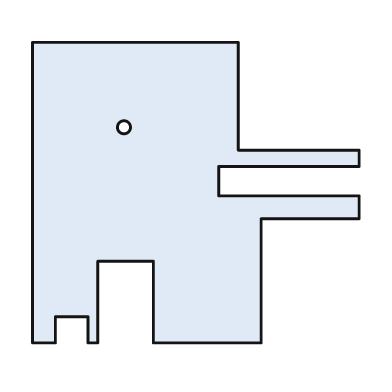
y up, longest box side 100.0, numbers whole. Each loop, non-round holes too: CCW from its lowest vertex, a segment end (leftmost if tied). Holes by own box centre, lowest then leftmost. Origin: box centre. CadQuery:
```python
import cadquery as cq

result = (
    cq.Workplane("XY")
    .moveTo(-50.0, -46.0)
    .lineTo(-43.0, -46.0)
    .lineTo(-43.0, -38.0)
    .lineTo(-33.0, -38.0)
    .lineTo(-33.0, -46.0)
    .lineTo(-30.0, -46.0)
    .lineTo(-30.0, -21.0)
    .lineTo(-13.0, -21.0)
    .lineTo(-13.0, -46.0)
    .lineTo(20.0, -46.0)
    .lineTo(20.0, -8.0)
    .lineTo(50.0, -8.0)
    .lineTo(50.0, -1.0)
    .lineTo(7.0, -1.0)
    .lineTo(7.0, 8.0)
    .lineTo(50.0, 8.0)
    .lineTo(50.0, 13.0)
    .lineTo(13.0, 13.0)
    .lineTo(13.0, 46.0)
    .lineTo(-50.0, 46.0)
    .close()
    .moveTo(-22.0, 20.0)
    .circle(2.0)
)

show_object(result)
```